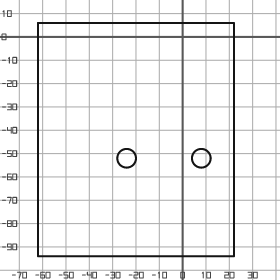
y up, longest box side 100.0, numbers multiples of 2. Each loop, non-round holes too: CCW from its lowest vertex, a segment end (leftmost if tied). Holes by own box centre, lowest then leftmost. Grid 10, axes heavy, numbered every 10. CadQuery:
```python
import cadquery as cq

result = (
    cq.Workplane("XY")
    .moveTo(-62.0, -94.0)
    .lineTo(22.0, -94.0)
    .lineTo(22.0, 6.0)
    .lineTo(-62.0, 6.0)
    .close()
    .moveTo(-24.0, -52.0)
    .circle(4.0)
    .moveTo(8.0, -52.0)
    .circle(4.0)
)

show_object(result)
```